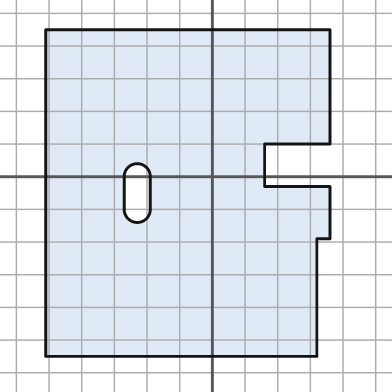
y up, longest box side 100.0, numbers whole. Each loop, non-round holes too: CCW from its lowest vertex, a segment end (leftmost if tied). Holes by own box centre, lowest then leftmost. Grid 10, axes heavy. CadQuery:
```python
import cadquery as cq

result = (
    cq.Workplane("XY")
    .moveTo(-51.0, -55.0)
    .lineTo(32.0, -55.0)
    .lineTo(32.0, -19.0)
    .lineTo(36.0, -19.0)
    .lineTo(36.0, -3.0)
    .lineTo(16.0, -3.0)
    .lineTo(16.0, 10.0)
    .lineTo(36.0, 10.0)
    .lineTo(36.0, 45.0)
    .lineTo(-51.0, 45.0)
    .close()
    .moveTo(-27.0, -10.0)
    .threePointArc((-23.0, -14.0), (-19.0, -10.0))
    .lineTo(-19.0, 0.0)
    .threePointArc((-23.0, 4.0), (-27.0, 0.0))
    .close()
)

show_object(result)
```